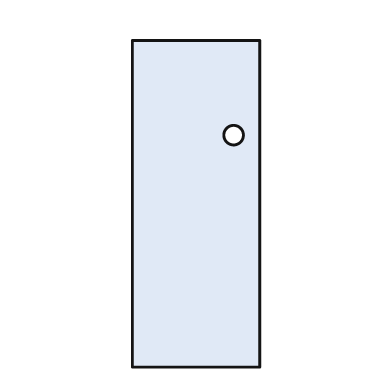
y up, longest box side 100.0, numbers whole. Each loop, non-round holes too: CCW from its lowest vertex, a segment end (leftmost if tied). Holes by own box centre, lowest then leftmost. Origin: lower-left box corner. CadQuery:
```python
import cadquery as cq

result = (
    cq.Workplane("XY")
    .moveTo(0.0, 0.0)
    .lineTo(39.0, 0.0)
    .lineTo(39.0, 100.0)
    .lineTo(0.0, 100.0)
    .close()
    .moveTo(31.0, 71.0)
    .circle(3.0)
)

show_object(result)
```